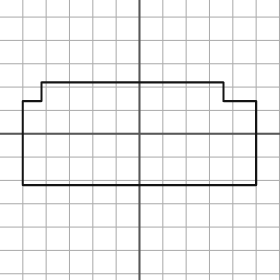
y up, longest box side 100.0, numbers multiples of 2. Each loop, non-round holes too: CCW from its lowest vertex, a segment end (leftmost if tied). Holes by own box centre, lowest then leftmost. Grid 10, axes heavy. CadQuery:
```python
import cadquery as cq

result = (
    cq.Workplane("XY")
    .moveTo(-50.0, -22.0)
    .lineTo(50.0, -22.0)
    .lineTo(50.0, 14.0)
    .lineTo(36.0, 14.0)
    .lineTo(36.0, 22.0)
    .lineTo(-42.0, 22.0)
    .lineTo(-42.0, 14.0)
    .lineTo(-50.0, 14.0)
    .close()
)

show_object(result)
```